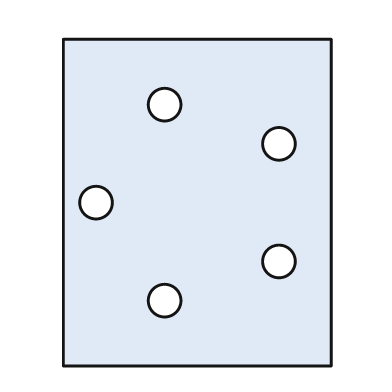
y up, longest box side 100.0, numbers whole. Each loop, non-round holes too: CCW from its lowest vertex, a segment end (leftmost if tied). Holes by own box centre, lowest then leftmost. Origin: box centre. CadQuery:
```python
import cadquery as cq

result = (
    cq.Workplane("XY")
    .moveTo(-41.0, -50.0)
    .lineTo(41.0, -50.0)
    .lineTo(41.0, 50.0)
    .lineTo(-41.0, 50.0)
    .close()
    .moveTo(-10.0, -30.0)
    .circle(5.0)
    .moveTo(25.0, -18.0)
    .circle(5.0)
    .moveTo(-31.0, 0.0)
    .circle(5.0)
    .moveTo(25.0, 18.0)
    .circle(5.0)
    .moveTo(-10.0, 30.0)
    .circle(5.0)
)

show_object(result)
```